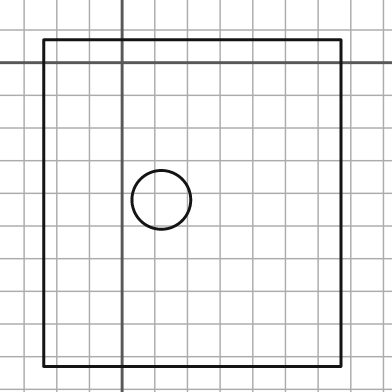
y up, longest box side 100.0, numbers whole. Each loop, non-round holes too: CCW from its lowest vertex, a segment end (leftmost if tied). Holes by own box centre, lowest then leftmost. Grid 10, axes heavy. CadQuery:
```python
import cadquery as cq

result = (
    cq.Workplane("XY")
    .moveTo(-24.0, -93.0)
    .lineTo(67.0, -93.0)
    .lineTo(67.0, 7.0)
    .lineTo(-24.0, 7.0)
    .close()
    .moveTo(12.0, -42.0)
    .circle(9.0)
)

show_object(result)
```